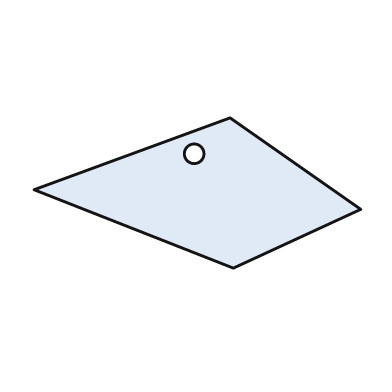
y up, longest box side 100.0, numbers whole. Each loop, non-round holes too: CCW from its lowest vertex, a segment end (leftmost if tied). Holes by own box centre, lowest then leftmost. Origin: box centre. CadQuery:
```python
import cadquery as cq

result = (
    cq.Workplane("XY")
    .moveTo(11.0, -23.0)
    .lineTo(50.0, -5.0)
    .lineTo(10.0, 23.0)
    .lineTo(-50.0, 1.0)
    .close()
    .moveTo(-1.0, 12.0)
    .circle(3.0)
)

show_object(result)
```